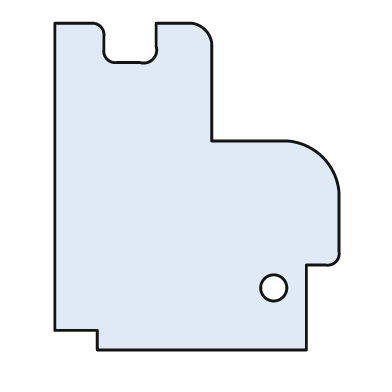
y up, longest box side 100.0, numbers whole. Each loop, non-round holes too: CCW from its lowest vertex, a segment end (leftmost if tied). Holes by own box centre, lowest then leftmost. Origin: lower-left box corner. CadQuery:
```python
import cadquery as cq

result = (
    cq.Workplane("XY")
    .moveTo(13.0, 0.0)
    .lineTo(77.0, 0.0)
    .lineTo(77.0, 26.0)
    .lineTo(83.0, 26.0)
    .threePointArc((86.0, 27.0), (87.0, 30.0))
    .lineTo(87.0, 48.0)
    .threePointArc((82.0, 59.0), (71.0, 64.0))
    .lineTo(48.0, 64.0)
    .lineTo(48.0, 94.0)
    .threePointArc((46.0, 98.0), (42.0, 100.0))
    .lineTo(31.0, 100.0)
    .lineTo(31.0, 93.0)
    .threePointArc((30.0, 89.0), (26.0, 88.0))
    .lineTo(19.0, 88.0)
    .threePointArc((16.0, 89.0), (15.0, 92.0))
    .lineTo(15.0, 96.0)
    .threePointArc((14.0, 99.0), (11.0, 100.0))
    .lineTo(0.0, 100.0)
    .lineTo(0.0, 6.0)
    .lineTo(13.0, 6.0)
    .close()
    .moveTo(67.0, 19.0)
    .circle(4.0)
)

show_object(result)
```